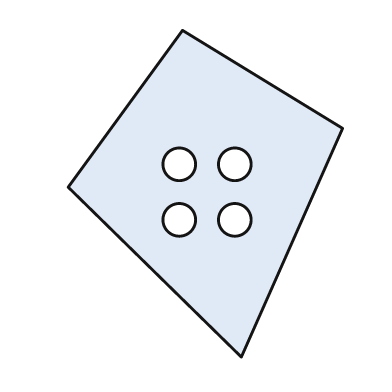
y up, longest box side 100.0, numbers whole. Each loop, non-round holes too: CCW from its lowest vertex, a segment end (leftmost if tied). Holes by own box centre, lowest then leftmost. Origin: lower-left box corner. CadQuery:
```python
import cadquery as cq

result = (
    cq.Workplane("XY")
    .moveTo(53.0, 0.0)
    .lineTo(84.0, 70.0)
    .lineTo(35.0, 100.0)
    .lineTo(0.0, 52.0)
    .close()
    .moveTo(34.0, 42.0)
    .circle(5.0)
    .moveTo(51.0, 42.0)
    .circle(5.0)
    .moveTo(34.0, 59.0)
    .circle(5.0)
    .moveTo(51.0, 59.0)
    .circle(5.0)
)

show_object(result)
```